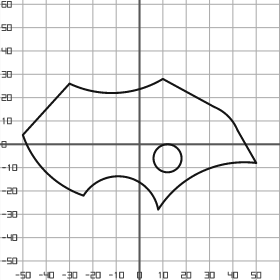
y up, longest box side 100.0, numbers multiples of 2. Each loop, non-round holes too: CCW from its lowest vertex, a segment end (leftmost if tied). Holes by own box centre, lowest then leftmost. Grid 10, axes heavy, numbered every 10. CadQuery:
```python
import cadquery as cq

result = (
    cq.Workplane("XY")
    .moveTo(8.0, -28.0)
    .threePointArc((26.0, -12.0), (50.0, -8.0))
    .lineTo(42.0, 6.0)
    .threePointArc((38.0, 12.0), (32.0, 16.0))
    .lineTo(10.0, 28.0)
    .threePointArc((-10.0, 22.0), (-30.0, 26.0))
    .lineTo(-50.0, 4.0)
    .threePointArc((-40.0, -12.0), (-24.0, -22.0))
    .threePointArc((-6.0, -14.0), (8.0, -28.0))
    .close()
    .moveTo(12.0, -6.0)
    .circle(6.0)
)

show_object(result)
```